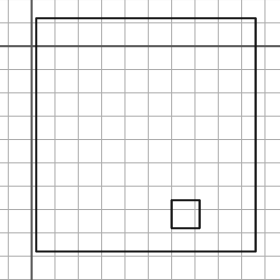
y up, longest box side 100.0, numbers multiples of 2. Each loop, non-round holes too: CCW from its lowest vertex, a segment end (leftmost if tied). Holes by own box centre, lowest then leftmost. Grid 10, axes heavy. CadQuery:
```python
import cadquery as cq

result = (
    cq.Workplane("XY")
    .moveTo(2.0, -88.0)
    .lineTo(96.0, -88.0)
    .lineTo(96.0, 12.0)
    .lineTo(2.0, 12.0)
    .close()
    .moveTo(60.0, -78.0)
    .lineTo(72.0, -78.0)
    .lineTo(72.0, -66.0)
    .lineTo(60.0, -66.0)
    .close()
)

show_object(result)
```